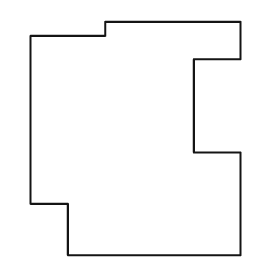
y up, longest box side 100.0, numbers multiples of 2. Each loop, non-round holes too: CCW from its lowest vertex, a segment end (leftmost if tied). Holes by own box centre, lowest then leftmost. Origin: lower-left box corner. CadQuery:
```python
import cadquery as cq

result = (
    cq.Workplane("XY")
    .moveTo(16.0, 0.0)
    .lineTo(90.0, 0.0)
    .lineTo(90.0, 44.0)
    .lineTo(70.0, 44.0)
    .lineTo(70.0, 84.0)
    .lineTo(90.0, 84.0)
    .lineTo(90.0, 100.0)
    .lineTo(32.0, 100.0)
    .lineTo(32.0, 94.0)
    .lineTo(0.0, 94.0)
    .lineTo(0.0, 22.0)
    .lineTo(16.0, 22.0)
    .close()
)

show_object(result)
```